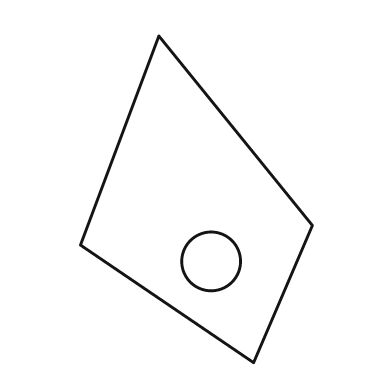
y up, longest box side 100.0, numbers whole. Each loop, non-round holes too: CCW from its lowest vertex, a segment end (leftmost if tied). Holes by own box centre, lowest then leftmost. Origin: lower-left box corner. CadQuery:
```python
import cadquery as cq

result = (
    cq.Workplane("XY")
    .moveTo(53.0, 0.0)
    .lineTo(71.0, 42.0)
    .lineTo(24.0, 100.0)
    .lineTo(0.0, 36.0)
    .close()
    .moveTo(40.0, 31.0)
    .circle(9.0)
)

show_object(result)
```